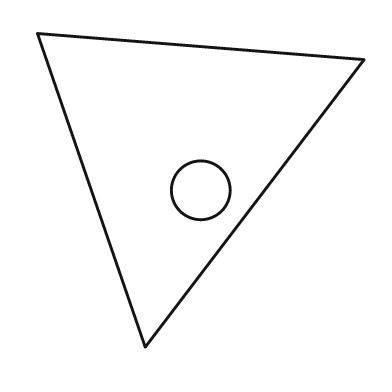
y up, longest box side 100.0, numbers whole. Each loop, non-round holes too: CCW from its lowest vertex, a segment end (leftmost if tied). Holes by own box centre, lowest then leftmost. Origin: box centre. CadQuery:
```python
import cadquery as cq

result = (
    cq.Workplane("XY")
    .moveTo(-17.0, -48.0)
    .lineTo(50.0, 40.0)
    .lineTo(-50.0, 48.0)
    .close()
    .moveTo(0.0, 0.0)
    .circle(9.0)
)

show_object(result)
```